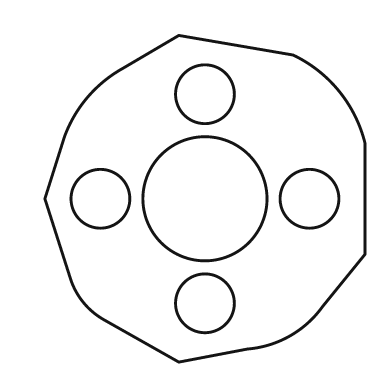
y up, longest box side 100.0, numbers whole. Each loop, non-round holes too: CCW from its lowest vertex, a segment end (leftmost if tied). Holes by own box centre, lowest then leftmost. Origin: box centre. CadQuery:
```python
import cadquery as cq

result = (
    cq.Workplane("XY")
    .moveTo(-8.0, -50.0)
    .lineTo(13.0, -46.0)
    .threePointArc((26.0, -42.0), (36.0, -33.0))
    .lineTo(49.0, -17.0)
    .lineTo(49.0, 17.0)
    .threePointArc((41.0, 33.0), (27.0, 44.0))
    .lineTo(-8.0, 50.0)
    .lineTo(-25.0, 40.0)
    .threePointArc((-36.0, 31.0), (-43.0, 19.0))
    .lineTo(-49.0, 0.0)
    .lineTo(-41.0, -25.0)
    .threePointArc((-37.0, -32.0), (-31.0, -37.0))
    .close()
    .moveTo(0.0, -32.0)
    .circle(9.0)
    .moveTo(-32.0, 0.0)
    .circle(9.0)
    .moveTo(0.0, 0.0)
    .circle(19.0)
    .moveTo(32.0, 0.0)
    .circle(9.0)
    .moveTo(0.0, 32.0)
    .circle(9.0)
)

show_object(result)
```